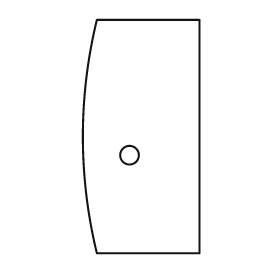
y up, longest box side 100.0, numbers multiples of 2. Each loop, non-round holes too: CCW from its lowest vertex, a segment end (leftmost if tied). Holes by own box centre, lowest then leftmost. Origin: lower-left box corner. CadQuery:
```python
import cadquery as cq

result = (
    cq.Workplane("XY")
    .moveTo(6.0, 0.0)
    .lineTo(50.0, 0.0)
    .lineTo(50.0, 100.0)
    .lineTo(6.0, 100.0)
    .threePointArc((0.0, 50.0), (6.0, 0.0))
    .close()
    .moveTo(20.0, 42.0)
    .circle(4.0)
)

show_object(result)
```